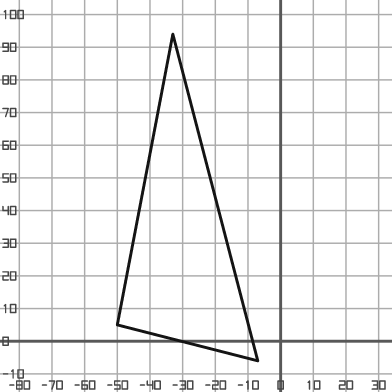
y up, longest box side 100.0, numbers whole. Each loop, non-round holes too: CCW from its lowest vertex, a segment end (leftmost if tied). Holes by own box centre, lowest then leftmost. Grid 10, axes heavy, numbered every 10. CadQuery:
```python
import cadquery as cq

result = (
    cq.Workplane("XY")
    .moveTo(-7.0, -6.0)
    .lineTo(-33.0, 94.0)
    .lineTo(-50.0, 5.0)
    .close()
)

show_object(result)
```